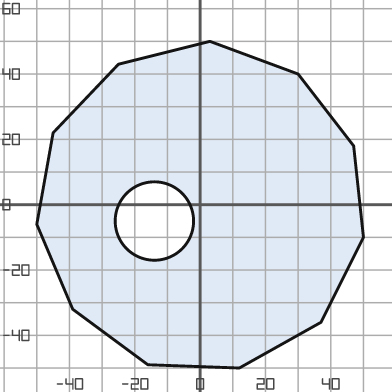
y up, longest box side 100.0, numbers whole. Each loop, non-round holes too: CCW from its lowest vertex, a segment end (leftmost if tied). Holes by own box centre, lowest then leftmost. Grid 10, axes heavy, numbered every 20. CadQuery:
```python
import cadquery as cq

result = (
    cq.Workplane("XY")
    .moveTo(12.0, -50.0)
    .lineTo(37.0, -36.0)
    .lineTo(50.0, -10.0)
    .lineTo(47.0, 18.0)
    .lineTo(30.0, 40.0)
    .lineTo(3.0, 50.0)
    .lineTo(-25.0, 43.0)
    .lineTo(-45.0, 22.0)
    .lineTo(-50.0, -6.0)
    .lineTo(-39.0, -32.0)
    .lineTo(-16.0, -49.0)
    .close()
    .moveTo(-14.0, -5.0)
    .circle(12.0)
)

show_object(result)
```